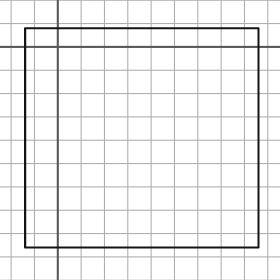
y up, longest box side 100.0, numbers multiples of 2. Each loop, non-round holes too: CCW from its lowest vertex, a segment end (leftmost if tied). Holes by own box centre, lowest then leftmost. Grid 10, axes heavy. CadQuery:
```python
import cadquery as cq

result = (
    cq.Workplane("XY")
    .moveTo(-14.0, -86.0)
    .lineTo(86.0, -86.0)
    .lineTo(86.0, 8.0)
    .lineTo(-14.0, 8.0)
    .close()
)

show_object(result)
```